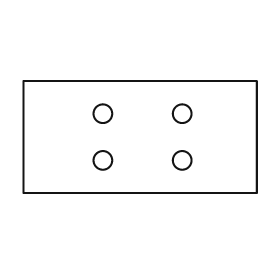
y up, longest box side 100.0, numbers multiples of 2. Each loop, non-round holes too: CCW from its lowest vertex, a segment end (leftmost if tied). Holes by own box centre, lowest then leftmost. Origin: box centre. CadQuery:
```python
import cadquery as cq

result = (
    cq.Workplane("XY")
    .moveTo(-50.0, -24.0)
    .lineTo(50.0, -24.0)
    .lineTo(50.0, 24.0)
    .lineTo(-50.0, 24.0)
    .close()
    .moveTo(-16.0, -10.0)
    .circle(4.0)
    .moveTo(18.0, -10.0)
    .circle(4.0)
    .moveTo(-16.0, 10.0)
    .circle(4.0)
    .moveTo(18.0, 10.0)
    .circle(4.0)
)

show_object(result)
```